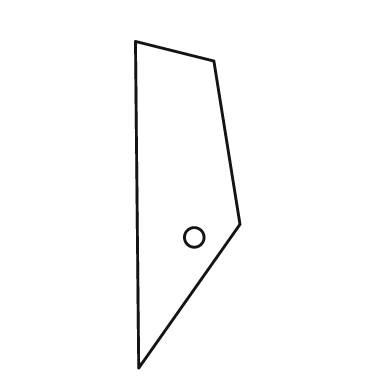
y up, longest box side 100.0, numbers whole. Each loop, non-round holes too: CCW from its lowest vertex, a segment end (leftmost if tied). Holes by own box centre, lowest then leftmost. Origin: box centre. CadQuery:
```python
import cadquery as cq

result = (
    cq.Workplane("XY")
    .moveTo(-15.0, -50.0)
    .lineTo(16.0, -6.0)
    .lineTo(8.0, 44.0)
    .lineTo(-16.0, 50.0)
    .close()
    .moveTo(2.0, -10.0)
    .circle(3.0)
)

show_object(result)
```